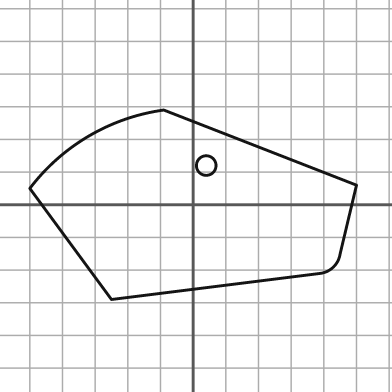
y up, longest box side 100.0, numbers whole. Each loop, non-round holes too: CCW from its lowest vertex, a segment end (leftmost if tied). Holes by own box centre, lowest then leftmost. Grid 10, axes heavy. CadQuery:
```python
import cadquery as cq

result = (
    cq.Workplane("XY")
    .moveTo(-25.0, -29.0)
    .lineTo(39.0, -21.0)
    .threePointArc((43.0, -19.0), (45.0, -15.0))
    .lineTo(50.0, 6.0)
    .lineTo(-9.0, 29.0)
    .threePointArc((-32.0, 21.0), (-50.0, 5.0))
    .close()
    .moveTo(4.0, 12.0)
    .circle(3.0)
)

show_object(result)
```